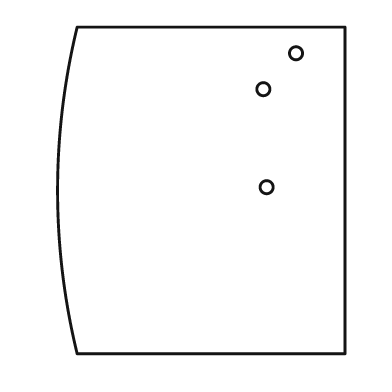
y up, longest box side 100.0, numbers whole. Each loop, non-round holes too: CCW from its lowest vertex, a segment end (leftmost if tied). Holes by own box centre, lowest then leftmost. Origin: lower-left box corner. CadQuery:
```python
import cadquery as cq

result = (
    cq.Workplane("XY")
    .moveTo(6.0, 0.0)
    .lineTo(88.0, 0.0)
    .lineTo(88.0, 100.0)
    .lineTo(6.0, 100.0)
    .threePointArc((0.0, 50.0), (6.0, 0.0))
    .close()
    .moveTo(64.0, 51.0)
    .circle(2.0)
    .moveTo(63.0, 81.0)
    .circle(2.0)
    .moveTo(73.0, 92.0)
    .circle(2.0)
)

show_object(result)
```